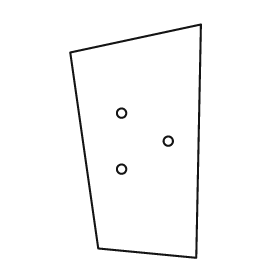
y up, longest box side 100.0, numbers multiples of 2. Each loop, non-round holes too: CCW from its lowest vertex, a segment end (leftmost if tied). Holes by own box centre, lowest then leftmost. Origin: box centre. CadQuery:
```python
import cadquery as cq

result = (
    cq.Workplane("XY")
    .moveTo(26.0, -50.0)
    .lineTo(28.0, 50.0)
    .lineTo(-28.0, 38.0)
    .lineTo(-16.0, -46.0)
    .close()
    .moveTo(-6.0, -12.0)
    .circle(2.0)
    .moveTo(14.0, 0.0)
    .circle(2.0)
    .moveTo(-6.0, 12.0)
    .circle(2.0)
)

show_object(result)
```